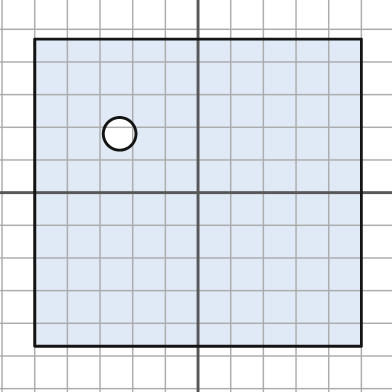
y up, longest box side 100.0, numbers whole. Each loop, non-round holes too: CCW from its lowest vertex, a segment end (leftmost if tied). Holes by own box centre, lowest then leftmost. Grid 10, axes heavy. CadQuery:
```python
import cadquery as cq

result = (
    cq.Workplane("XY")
    .moveTo(-50.0, -47.0)
    .lineTo(50.0, -47.0)
    .lineTo(50.0, 47.0)
    .lineTo(-50.0, 47.0)
    .close()
    .moveTo(-24.0, 18.0)
    .circle(5.0)
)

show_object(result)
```